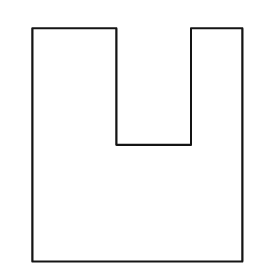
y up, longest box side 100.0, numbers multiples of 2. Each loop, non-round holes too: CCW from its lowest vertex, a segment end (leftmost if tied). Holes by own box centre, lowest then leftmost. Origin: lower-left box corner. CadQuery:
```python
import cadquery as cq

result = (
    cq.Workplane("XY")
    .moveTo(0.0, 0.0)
    .lineTo(90.0, 0.0)
    .lineTo(90.0, 100.0)
    .lineTo(68.0, 100.0)
    .lineTo(68.0, 50.0)
    .lineTo(36.0, 50.0)
    .lineTo(36.0, 100.0)
    .lineTo(0.0, 100.0)
    .close()
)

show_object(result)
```